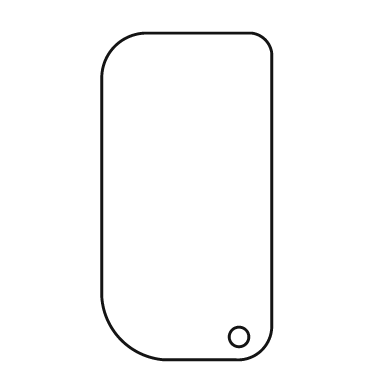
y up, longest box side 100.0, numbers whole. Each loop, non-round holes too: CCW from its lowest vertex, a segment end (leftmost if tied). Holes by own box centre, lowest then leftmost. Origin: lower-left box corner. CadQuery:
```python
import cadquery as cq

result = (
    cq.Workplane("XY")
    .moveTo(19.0, 0.0)
    .lineTo(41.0, 0.0)
    .threePointArc((49.0, 3.0), (52.0, 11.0))
    .lineTo(52.0, 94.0)
    .threePointArc((50.0, 98.0), (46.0, 100.0))
    .lineTo(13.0, 100.0)
    .threePointArc((4.0, 96.0), (0.0, 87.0))
    .lineTo(0.0, 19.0)
    .threePointArc((6.0, 6.0), (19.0, 0.0))
    .close()
    .moveTo(42.0, 7.0)
    .circle(3.0)
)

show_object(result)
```